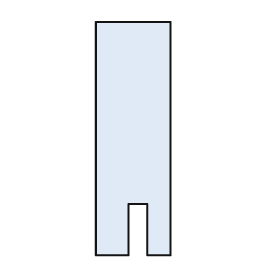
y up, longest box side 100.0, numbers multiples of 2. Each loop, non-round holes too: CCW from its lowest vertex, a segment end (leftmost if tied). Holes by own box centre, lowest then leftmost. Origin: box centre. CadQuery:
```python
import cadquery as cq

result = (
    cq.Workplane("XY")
    .moveTo(-16.0, -50.0)
    .lineTo(-2.0, -50.0)
    .lineTo(-2.0, -28.0)
    .lineTo(6.0, -28.0)
    .lineTo(6.0, -50.0)
    .lineTo(16.0, -50.0)
    .lineTo(16.0, 50.0)
    .lineTo(-16.0, 50.0)
    .close()
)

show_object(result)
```